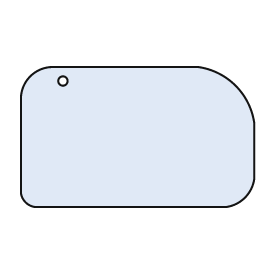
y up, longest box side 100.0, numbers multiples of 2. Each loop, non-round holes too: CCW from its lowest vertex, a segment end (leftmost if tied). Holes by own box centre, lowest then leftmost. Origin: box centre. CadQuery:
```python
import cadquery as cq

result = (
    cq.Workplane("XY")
    .moveTo(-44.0, -30.0)
    .lineTo(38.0, -30.0)
    .threePointArc((46.0, -26.0), (50.0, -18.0))
    .lineTo(50.0, 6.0)
    .threePointArc((42.0, 22.0), (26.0, 30.0))
    .lineTo(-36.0, 30.0)
    .threePointArc((-46.0, 26.0), (-50.0, 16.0))
    .lineTo(-50.0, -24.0)
    .threePointArc((-48.0, -28.0), (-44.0, -30.0))
    .close()
    .moveTo(-32.0, 24.0)
    .circle(2.0)
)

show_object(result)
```